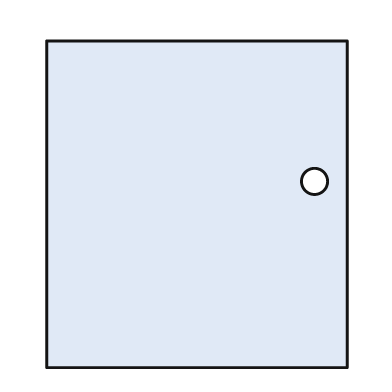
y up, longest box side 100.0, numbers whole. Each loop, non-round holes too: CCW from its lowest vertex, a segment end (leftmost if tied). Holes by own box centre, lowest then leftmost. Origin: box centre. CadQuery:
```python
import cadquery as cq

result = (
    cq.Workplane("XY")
    .moveTo(-46.0, -50.0)
    .lineTo(46.0, -50.0)
    .lineTo(46.0, 50.0)
    .lineTo(-46.0, 50.0)
    .close()
    .moveTo(36.0, 7.0)
    .circle(4.0)
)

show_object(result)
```